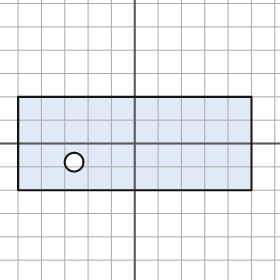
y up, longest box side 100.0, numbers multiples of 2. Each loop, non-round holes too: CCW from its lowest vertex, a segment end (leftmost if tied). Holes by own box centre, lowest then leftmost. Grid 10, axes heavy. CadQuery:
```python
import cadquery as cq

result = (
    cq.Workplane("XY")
    .moveTo(-50.0, -20.0)
    .lineTo(50.0, -20.0)
    .lineTo(50.0, 20.0)
    .lineTo(-50.0, 20.0)
    .close()
    .moveTo(-26.0, -8.0)
    .circle(4.0)
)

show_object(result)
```